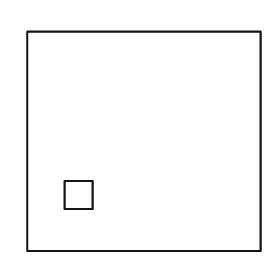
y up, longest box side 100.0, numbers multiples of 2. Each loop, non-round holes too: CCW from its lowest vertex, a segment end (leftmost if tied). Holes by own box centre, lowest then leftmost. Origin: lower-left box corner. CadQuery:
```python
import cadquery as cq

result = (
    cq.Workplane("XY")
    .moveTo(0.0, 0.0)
    .lineTo(100.0, 0.0)
    .lineTo(100.0, 94.0)
    .lineTo(0.0, 94.0)
    .close()
    .moveTo(16.0, 18.0)
    .lineTo(28.0, 18.0)
    .lineTo(28.0, 30.0)
    .lineTo(16.0, 30.0)
    .close()
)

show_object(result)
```